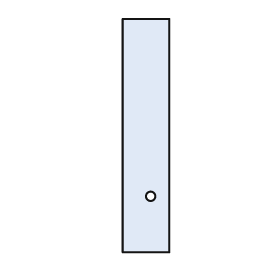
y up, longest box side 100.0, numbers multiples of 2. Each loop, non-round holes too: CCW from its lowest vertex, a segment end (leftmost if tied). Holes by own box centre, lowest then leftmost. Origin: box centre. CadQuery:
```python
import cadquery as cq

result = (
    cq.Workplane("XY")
    .moveTo(-10.0, -50.0)
    .lineTo(10.0, -50.0)
    .lineTo(10.0, 50.0)
    .lineTo(-10.0, 50.0)
    .close()
    .moveTo(2.0, -26.0)
    .circle(2.0)
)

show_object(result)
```